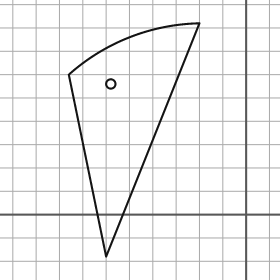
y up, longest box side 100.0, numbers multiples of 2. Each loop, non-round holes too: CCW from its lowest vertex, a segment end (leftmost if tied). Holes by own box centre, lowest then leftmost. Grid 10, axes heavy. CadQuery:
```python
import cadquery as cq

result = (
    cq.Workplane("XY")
    .moveTo(-60.0, -18.0)
    .lineTo(-20.0, 82.0)
    .threePointArc((-50.0, 76.0), (-76.0, 60.0))
    .close()
    .moveTo(-58.0, 56.0)
    .circle(2.0)
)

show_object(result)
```